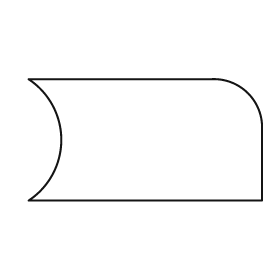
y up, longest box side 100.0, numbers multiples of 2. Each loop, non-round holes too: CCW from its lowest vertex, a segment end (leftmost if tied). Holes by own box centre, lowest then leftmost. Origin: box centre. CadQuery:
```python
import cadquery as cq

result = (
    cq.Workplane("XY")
    .moveTo(-50.0, -26.0)
    .lineTo(50.0, -26.0)
    .lineTo(50.0, 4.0)
    .threePointArc((44.0, 20.0), (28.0, 26.0))
    .lineTo(-50.0, 26.0)
    .threePointArc((-36.0, 0.0), (-50.0, -26.0))
    .close()
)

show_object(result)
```